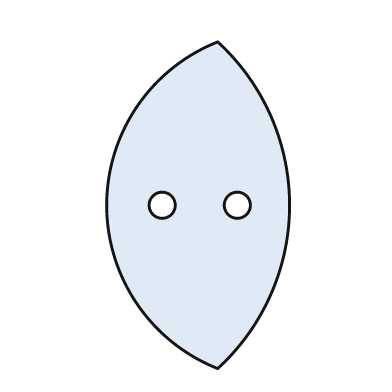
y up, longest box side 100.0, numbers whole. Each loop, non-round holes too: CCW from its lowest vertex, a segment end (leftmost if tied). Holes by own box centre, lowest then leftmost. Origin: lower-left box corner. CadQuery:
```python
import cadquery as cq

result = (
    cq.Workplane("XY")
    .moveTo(34.0, 0.0)
    .threePointArc((56.0, 50.0), (34.0, 100.0))
    .threePointArc((0.0, 50.0), (34.0, 0.0))
    .close()
    .moveTo(17.0, 50.0)
    .circle(4.0)
    .moveTo(40.0, 50.0)
    .circle(4.0)
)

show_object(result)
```